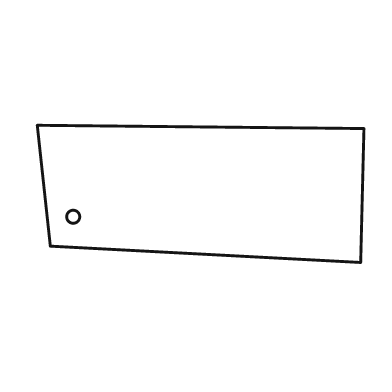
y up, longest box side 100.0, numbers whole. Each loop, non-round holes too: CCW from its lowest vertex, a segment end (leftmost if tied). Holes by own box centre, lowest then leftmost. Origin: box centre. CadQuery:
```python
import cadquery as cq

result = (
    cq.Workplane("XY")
    .moveTo(49.0, -21.0)
    .lineTo(50.0, 20.0)
    .lineTo(-50.0, 21.0)
    .lineTo(-46.0, -16.0)
    .close()
    .moveTo(-39.0, -7.0)
    .circle(2.0)
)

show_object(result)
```